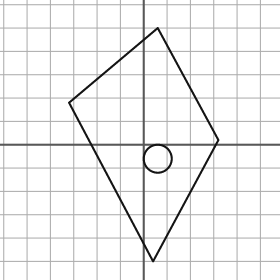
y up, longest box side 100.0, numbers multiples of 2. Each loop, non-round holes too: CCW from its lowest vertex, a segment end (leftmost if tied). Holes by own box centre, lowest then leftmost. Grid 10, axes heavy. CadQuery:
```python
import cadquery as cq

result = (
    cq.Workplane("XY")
    .moveTo(4.0, -50.0)
    .lineTo(32.0, 2.0)
    .lineTo(6.0, 50.0)
    .lineTo(-32.0, 18.0)
    .close()
    .moveTo(6.0, -6.0)
    .circle(6.0)
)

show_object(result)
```